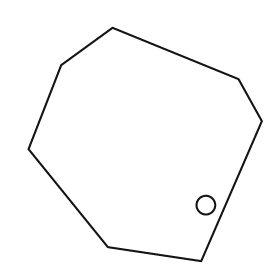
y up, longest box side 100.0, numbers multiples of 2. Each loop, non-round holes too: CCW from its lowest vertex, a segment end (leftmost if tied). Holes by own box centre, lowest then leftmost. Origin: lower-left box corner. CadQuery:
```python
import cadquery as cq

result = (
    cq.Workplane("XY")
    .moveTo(74.0, 0.0)
    .lineTo(100.0, 60.0)
    .lineTo(90.0, 78.0)
    .lineTo(36.0, 100.0)
    .lineTo(14.0, 84.0)
    .lineTo(0.0, 48.0)
    .lineTo(34.0, 6.0)
    .close()
    .moveTo(76.0, 24.0)
    .circle(4.0)
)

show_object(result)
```